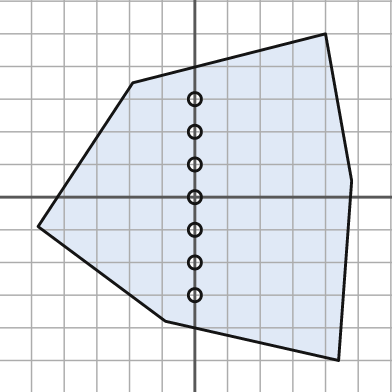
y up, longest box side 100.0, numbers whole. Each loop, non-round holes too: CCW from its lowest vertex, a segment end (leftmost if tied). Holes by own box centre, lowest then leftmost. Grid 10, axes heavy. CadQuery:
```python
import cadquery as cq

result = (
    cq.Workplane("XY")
    .moveTo(44.0, -50.0)
    .lineTo(48.0, 5.0)
    .lineTo(40.0, 50.0)
    .lineTo(-19.0, 35.0)
    .lineTo(-48.0, -9.0)
    .lineTo(-9.0, -38.0)
    .close()
    .moveTo(0.0, -30.0)
    .circle(2.0)
    .moveTo(0.0, -20.0)
    .circle(2.0)
    .moveTo(0.0, -10.0)
    .circle(2.0)
    .moveTo(0.0, 0.0)
    .circle(2.0)
    .moveTo(0.0, 10.0)
    .circle(2.0)
    .moveTo(0.0, 20.0)
    .circle(2.0)
    .moveTo(0.0, 30.0)
    .circle(2.0)
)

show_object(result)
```